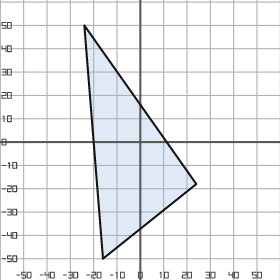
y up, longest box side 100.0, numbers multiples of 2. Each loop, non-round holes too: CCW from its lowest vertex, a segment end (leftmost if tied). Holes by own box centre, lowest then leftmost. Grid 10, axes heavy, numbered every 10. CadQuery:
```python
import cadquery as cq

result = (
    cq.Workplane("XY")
    .moveTo(-16.0, -50.0)
    .lineTo(24.0, -18.0)
    .lineTo(-24.0, 50.0)
    .close()
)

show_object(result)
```